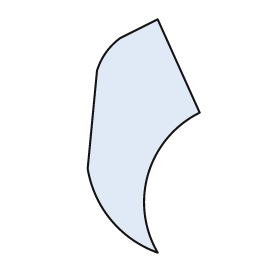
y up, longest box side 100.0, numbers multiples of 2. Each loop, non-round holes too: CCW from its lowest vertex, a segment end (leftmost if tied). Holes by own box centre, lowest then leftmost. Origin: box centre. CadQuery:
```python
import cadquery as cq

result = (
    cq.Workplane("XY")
    .moveTo(6.0, -50.0)
    .threePointArc((2.0, -16.0), (24.0, 10.0))
    .lineTo(6.0, 50.0)
    .lineTo(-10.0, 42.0)
    .threePointArc((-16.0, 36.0), (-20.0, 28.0))
    .lineTo(-24.0, -14.0)
    .threePointArc((-14.0, -36.0), (6.0, -50.0))
    .close()
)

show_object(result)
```